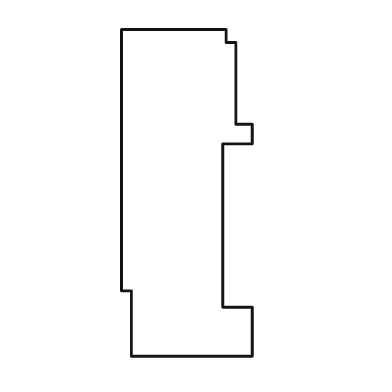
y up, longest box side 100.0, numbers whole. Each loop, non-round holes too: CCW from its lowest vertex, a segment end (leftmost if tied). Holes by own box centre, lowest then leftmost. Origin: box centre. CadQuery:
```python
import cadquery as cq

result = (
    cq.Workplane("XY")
    .moveTo(-17.0, -50.0)
    .lineTo(20.0, -50.0)
    .lineTo(20.0, -35.0)
    .lineTo(11.0, -35.0)
    .lineTo(11.0, 15.0)
    .lineTo(20.0, 15.0)
    .lineTo(20.0, 21.0)
    .lineTo(15.0, 21.0)
    .lineTo(15.0, 46.0)
    .lineTo(12.0, 46.0)
    .lineTo(12.0, 50.0)
    .lineTo(-20.0, 50.0)
    .lineTo(-20.0, -30.0)
    .lineTo(-17.0, -30.0)
    .close()
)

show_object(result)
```